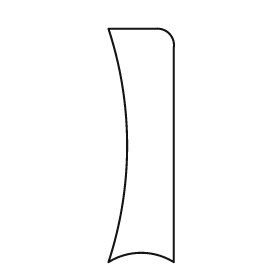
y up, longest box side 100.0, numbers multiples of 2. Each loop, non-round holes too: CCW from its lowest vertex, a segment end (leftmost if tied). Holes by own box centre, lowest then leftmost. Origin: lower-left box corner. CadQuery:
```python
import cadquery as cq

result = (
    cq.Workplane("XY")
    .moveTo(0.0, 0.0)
    .threePointArc((14.0, 4.0), (28.0, 0.0))
    .lineTo(28.0, 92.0)
    .threePointArc((26.0, 98.0), (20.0, 100.0))
    .lineTo(0.0, 100.0)
    .threePointArc((8.0, 50.0), (0.0, 0.0))
    .close()
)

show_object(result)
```